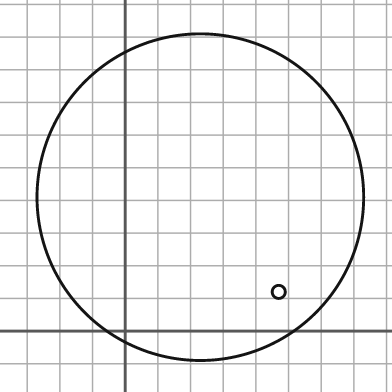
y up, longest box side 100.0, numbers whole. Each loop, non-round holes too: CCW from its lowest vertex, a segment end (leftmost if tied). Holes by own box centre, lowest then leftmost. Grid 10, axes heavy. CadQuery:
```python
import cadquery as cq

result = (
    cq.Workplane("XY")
    .moveTo(23.0, 41.0)
    .circle(50.0)
    .moveTo(47.0, 12.0)
    .circle(2.0)
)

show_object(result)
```